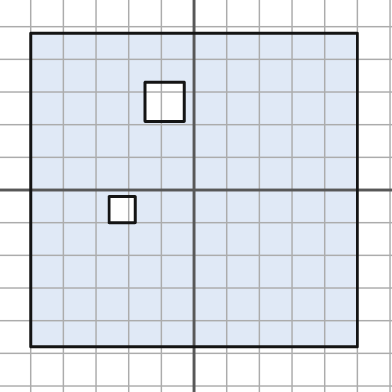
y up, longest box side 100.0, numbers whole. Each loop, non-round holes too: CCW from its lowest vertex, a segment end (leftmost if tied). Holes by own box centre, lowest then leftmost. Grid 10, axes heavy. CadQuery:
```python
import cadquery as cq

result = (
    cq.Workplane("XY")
    .moveTo(-50.0, -48.0)
    .lineTo(50.0, -48.0)
    .lineTo(50.0, 48.0)
    .lineTo(-50.0, 48.0)
    .close()
    .moveTo(-26.0, -10.0)
    .lineTo(-18.0, -10.0)
    .lineTo(-18.0, -2.0)
    .lineTo(-26.0, -2.0)
    .close()
    .moveTo(-15.0, 21.0)
    .lineTo(-3.0, 21.0)
    .lineTo(-3.0, 33.0)
    .lineTo(-15.0, 33.0)
    .close()
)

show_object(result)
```